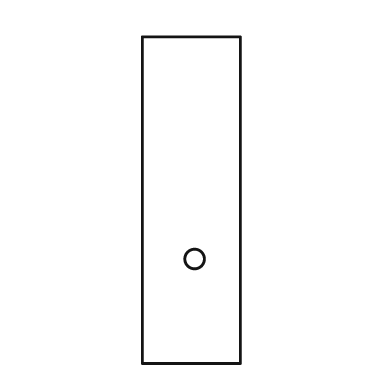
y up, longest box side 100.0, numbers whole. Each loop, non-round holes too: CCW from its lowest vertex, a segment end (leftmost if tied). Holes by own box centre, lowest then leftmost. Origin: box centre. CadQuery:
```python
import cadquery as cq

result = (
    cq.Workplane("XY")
    .moveTo(-15.0, -50.0)
    .lineTo(15.0, -50.0)
    .lineTo(15.0, 50.0)
    .lineTo(-15.0, 50.0)
    .close()
    .moveTo(1.0, -18.0)
    .circle(3.0)
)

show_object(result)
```